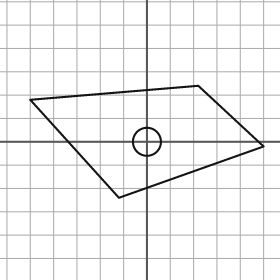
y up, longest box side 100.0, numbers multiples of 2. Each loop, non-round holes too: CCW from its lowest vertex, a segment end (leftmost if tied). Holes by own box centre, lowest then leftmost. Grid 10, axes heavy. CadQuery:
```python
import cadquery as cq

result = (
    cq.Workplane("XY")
    .moveTo(-12.0, -24.0)
    .lineTo(50.0, -2.0)
    .lineTo(22.0, 24.0)
    .lineTo(-50.0, 18.0)
    .close()
    .moveTo(0.0, 0.0)
    .circle(6.0)
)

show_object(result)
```